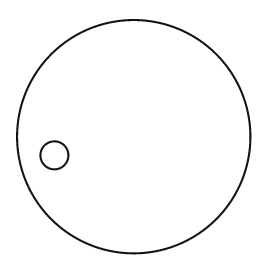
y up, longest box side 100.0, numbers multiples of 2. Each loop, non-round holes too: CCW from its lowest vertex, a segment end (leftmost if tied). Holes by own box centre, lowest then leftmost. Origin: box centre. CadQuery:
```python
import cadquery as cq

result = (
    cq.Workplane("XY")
    .moveTo(0.0, 0.0)
    .circle(50.0)
    .moveTo(-34.0, -8.0)
    .circle(6.0)
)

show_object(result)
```